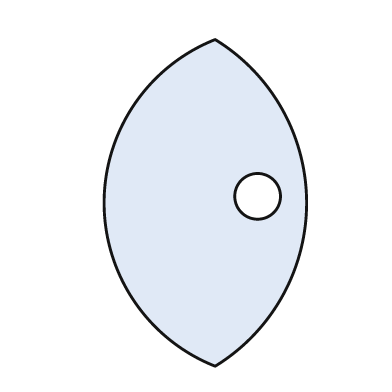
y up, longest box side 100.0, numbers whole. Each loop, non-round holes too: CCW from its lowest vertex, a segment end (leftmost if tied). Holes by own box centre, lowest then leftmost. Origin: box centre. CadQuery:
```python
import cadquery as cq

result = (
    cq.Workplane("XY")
    .moveTo(3.0, -50.0)
    .threePointArc((31.0, 0.0), (3.0, 50.0))
    .threePointArc((-31.0, 0.0), (3.0, -50.0))
    .close()
    .moveTo(16.0, 2.0)
    .circle(7.0)
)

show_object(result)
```